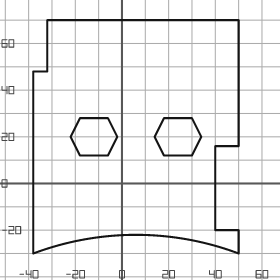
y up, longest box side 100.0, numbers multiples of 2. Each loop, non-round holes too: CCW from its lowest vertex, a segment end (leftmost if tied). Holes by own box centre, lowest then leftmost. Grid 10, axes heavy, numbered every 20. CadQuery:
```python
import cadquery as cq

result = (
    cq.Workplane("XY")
    .moveTo(-38.0, -30.0)
    .threePointArc((6.0, -22.0), (50.0, -30.0))
    .lineTo(50.0, -20.0)
    .lineTo(40.0, -20.0)
    .lineTo(40.0, 16.0)
    .lineTo(50.0, 16.0)
    .lineTo(50.0, 70.0)
    .lineTo(-32.0, 70.0)
    .lineTo(-32.0, 48.0)
    .lineTo(-38.0, 48.0)
    .close()
    .moveTo(-18.0, 12.0)
    .lineTo(-6.0, 12.0)
    .lineTo(-2.0, 20.0)
    .lineTo(-6.0, 28.0)
    .lineTo(-18.0, 28.0)
    .lineTo(-22.0, 20.0)
    .close()
    .moveTo(18.0, 12.0)
    .lineTo(30.0, 12.0)
    .lineTo(34.0, 20.0)
    .lineTo(30.0, 28.0)
    .lineTo(18.0, 28.0)
    .lineTo(14.0, 20.0)
    .close()
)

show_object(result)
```